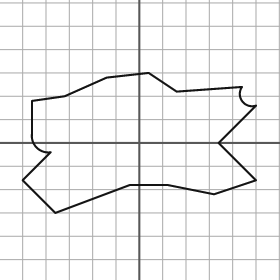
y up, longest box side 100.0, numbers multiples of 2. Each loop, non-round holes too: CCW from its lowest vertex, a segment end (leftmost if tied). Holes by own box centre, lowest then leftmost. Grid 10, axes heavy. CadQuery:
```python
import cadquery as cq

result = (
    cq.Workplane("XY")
    .moveTo(-36.0, -30.0)
    .lineTo(-4.0, -18.0)
    .lineTo(12.0, -18.0)
    .lineTo(32.0, -22.0)
    .lineTo(50.0, -16.0)
    .lineTo(34.0, 0.0)
    .lineTo(50.0, 16.0)
    .threePointArc((44.0, 18.0), (44.0, 24.0))
    .lineTo(16.0, 22.0)
    .lineTo(4.0, 30.0)
    .lineTo(-14.0, 28.0)
    .lineTo(-32.0, 20.0)
    .lineTo(-46.0, 18.0)
    .lineTo(-46.0, 4.0)
    .threePointArc((-44.0, -2.0), (-38.0, -4.0))
    .lineTo(-50.0, -16.0)
    .close()
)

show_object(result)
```